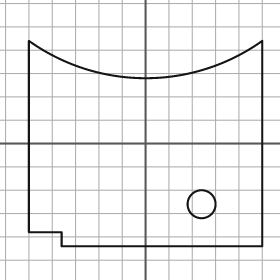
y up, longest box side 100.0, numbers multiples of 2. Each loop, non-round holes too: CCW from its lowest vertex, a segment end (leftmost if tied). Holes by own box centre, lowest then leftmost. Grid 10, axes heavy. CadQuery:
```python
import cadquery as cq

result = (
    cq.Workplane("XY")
    .moveTo(-36.0, -44.0)
    .lineTo(50.0, -44.0)
    .lineTo(50.0, 44.0)
    .threePointArc((0.0, 28.0), (-50.0, 44.0))
    .lineTo(-50.0, -38.0)
    .lineTo(-36.0, -38.0)
    .close()
    .moveTo(24.0, -26.0)
    .circle(6.0)
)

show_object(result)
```